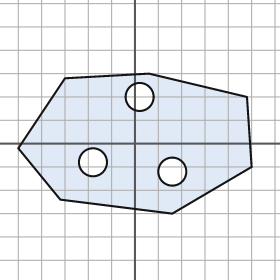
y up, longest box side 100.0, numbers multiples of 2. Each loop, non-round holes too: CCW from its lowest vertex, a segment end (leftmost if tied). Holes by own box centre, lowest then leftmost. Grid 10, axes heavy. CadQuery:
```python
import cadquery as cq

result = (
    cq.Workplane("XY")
    .moveTo(16.0, -30.0)
    .lineTo(50.0, -10.0)
    .lineTo(48.0, 20.0)
    .lineTo(6.0, 30.0)
    .lineTo(-30.0, 28.0)
    .lineTo(-50.0, -2.0)
    .lineTo(-32.0, -24.0)
    .close()
    .moveTo(16.0, -12.0)
    .circle(6.0)
    .moveTo(-18.0, -8.0)
    .circle(6.0)
    .moveTo(2.0, 20.0)
    .circle(6.0)
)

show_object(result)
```